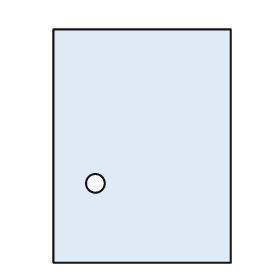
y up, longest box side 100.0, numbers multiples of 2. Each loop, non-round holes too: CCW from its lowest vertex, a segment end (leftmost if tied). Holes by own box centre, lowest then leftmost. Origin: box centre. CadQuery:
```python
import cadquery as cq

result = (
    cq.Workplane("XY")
    .moveTo(-38.0, -50.0)
    .lineTo(38.0, -50.0)
    .lineTo(38.0, 50.0)
    .lineTo(-38.0, 50.0)
    .close()
    .moveTo(-20.0, -16.0)
    .circle(4.0)
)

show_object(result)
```